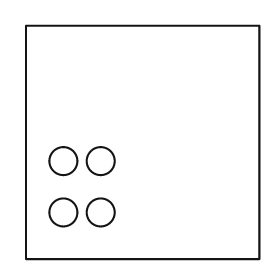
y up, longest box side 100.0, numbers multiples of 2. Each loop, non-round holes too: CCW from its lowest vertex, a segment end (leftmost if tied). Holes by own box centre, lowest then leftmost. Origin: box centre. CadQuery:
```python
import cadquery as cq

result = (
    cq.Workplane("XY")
    .moveTo(-50.0, -50.0)
    .lineTo(50.0, -50.0)
    .lineTo(50.0, 50.0)
    .lineTo(-50.0, 50.0)
    .close()
    .moveTo(-34.0, -30.0)
    .circle(6.0)
    .moveTo(-18.0, -30.0)
    .circle(6.0)
    .moveTo(-34.0, -8.0)
    .circle(6.0)
    .moveTo(-18.0, -8.0)
    .circle(6.0)
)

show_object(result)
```